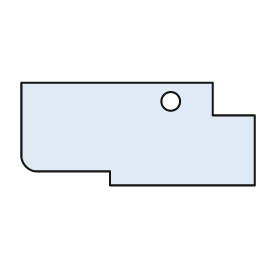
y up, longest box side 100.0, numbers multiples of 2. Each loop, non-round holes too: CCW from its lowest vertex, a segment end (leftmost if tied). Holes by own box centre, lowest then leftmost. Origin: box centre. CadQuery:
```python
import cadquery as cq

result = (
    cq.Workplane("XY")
    .moveTo(-12.0, -22.0)
    .lineTo(50.0, -22.0)
    .lineTo(50.0, 8.0)
    .lineTo(32.0, 8.0)
    .lineTo(32.0, 22.0)
    .lineTo(-50.0, 22.0)
    .lineTo(-50.0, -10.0)
    .threePointArc((-48.0, -14.0), (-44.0, -16.0))
    .lineTo(-12.0, -16.0)
    .close()
    .moveTo(14.0, 14.0)
    .circle(4.0)
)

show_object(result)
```